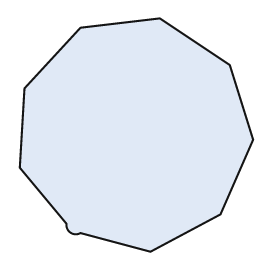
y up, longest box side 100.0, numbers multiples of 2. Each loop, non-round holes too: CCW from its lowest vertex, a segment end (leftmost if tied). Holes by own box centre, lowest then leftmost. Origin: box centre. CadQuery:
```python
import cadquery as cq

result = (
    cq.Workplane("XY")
    .moveTo(6.0, -50.0)
    .lineTo(36.0, -34.0)
    .lineTo(50.0, -2.0)
    .lineTo(40.0, 30.0)
    .lineTo(10.0, 50.0)
    .lineTo(-24.0, 46.0)
    .lineTo(-48.0, 20.0)
    .lineTo(-50.0, -14.0)
    .lineTo(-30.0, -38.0)
    .threePointArc((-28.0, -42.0), (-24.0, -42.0))
    .close()
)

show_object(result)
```